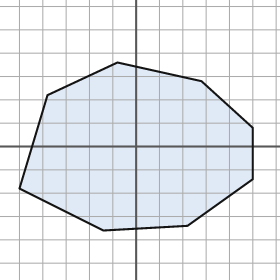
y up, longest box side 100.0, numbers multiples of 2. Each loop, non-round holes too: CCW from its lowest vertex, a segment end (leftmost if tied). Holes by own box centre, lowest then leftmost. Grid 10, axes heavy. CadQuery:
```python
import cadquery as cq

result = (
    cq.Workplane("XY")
    .moveTo(-14.0, -36.0)
    .lineTo(22.0, -34.0)
    .lineTo(50.0, -14.0)
    .lineTo(50.0, 8.0)
    .lineTo(28.0, 28.0)
    .lineTo(-8.0, 36.0)
    .lineTo(-38.0, 22.0)
    .lineTo(-50.0, -18.0)
    .close()
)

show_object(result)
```